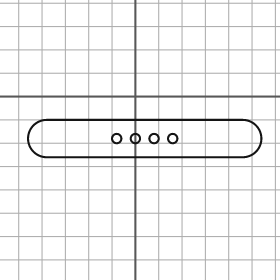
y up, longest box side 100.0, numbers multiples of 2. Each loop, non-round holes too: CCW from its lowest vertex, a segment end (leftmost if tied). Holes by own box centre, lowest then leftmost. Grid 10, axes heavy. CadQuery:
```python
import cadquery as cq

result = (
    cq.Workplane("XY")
    .moveTo(-38.0, -26.0)
    .lineTo(46.0, -26.0)
    .threePointArc((54.0, -18.0), (46.0, -10.0))
    .lineTo(-38.0, -10.0)
    .threePointArc((-46.0, -18.0), (-38.0, -26.0))
    .close()
    .moveTo(-8.0, -18.0)
    .circle(2.0)
    .moveTo(0.0, -18.0)
    .circle(2.0)
    .moveTo(8.0, -18.0)
    .circle(2.0)
    .moveTo(16.0, -18.0)
    .circle(2.0)
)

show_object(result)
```